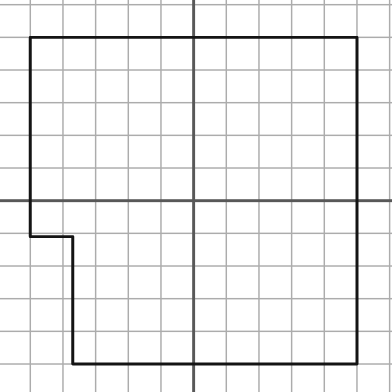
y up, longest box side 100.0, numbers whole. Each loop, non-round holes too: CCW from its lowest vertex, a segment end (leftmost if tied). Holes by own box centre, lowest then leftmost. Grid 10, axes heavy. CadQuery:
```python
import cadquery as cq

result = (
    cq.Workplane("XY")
    .moveTo(-37.0, -50.0)
    .lineTo(50.0, -50.0)
    .lineTo(50.0, 50.0)
    .lineTo(-50.0, 50.0)
    .lineTo(-50.0, -11.0)
    .lineTo(-37.0, -11.0)
    .close()
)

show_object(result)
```